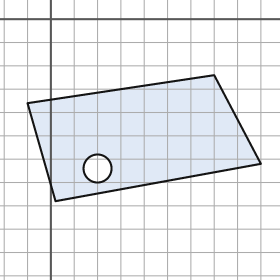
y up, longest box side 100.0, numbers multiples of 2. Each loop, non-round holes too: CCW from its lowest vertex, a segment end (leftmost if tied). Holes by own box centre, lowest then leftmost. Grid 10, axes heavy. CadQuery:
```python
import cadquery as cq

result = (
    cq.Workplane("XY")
    .moveTo(2.0, -78.0)
    .lineTo(90.0, -62.0)
    .lineTo(70.0, -24.0)
    .lineTo(-10.0, -36.0)
    .close()
    .moveTo(20.0, -64.0)
    .circle(6.0)
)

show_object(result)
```